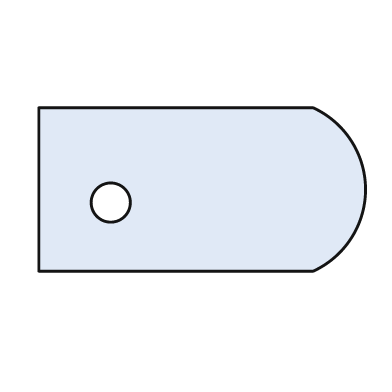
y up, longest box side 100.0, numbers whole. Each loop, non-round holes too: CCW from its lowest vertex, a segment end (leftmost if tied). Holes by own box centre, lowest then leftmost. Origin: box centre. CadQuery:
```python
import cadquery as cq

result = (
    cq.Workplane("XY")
    .moveTo(-50.0, -25.0)
    .lineTo(34.0, -25.0)
    .threePointArc((50.0, 0.0), (34.0, 25.0))
    .lineTo(-50.0, 25.0)
    .close()
    .moveTo(-28.0, -4.0)
    .circle(6.0)
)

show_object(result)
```